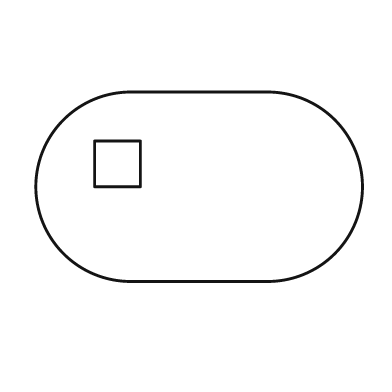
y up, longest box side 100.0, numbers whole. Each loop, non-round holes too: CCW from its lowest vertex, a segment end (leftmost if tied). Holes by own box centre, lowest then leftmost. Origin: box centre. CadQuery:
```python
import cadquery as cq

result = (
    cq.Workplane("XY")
    .moveTo(-21.0, -29.0)
    .lineTo(21.0, -29.0)
    .threePointArc((50.0, 0.0), (21.0, 29.0))
    .lineTo(-21.0, 29.0)
    .threePointArc((-50.0, 0.0), (-21.0, -29.0))
    .close()
    .moveTo(-32.0, 0.0)
    .lineTo(-18.0, 0.0)
    .lineTo(-18.0, 14.0)
    .lineTo(-32.0, 14.0)
    .close()
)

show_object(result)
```